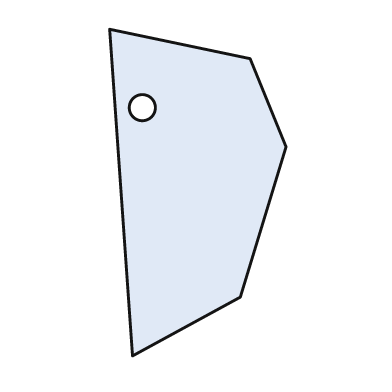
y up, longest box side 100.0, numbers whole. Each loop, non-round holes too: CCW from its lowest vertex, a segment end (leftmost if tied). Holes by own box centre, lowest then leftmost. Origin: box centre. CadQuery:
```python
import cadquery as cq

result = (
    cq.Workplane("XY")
    .moveTo(-20.0, -50.0)
    .lineTo(13.0, -32.0)
    .lineTo(27.0, 14.0)
    .lineTo(16.0, 41.0)
    .lineTo(-27.0, 50.0)
    .close()
    .moveTo(-17.0, 26.0)
    .circle(4.0)
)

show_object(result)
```